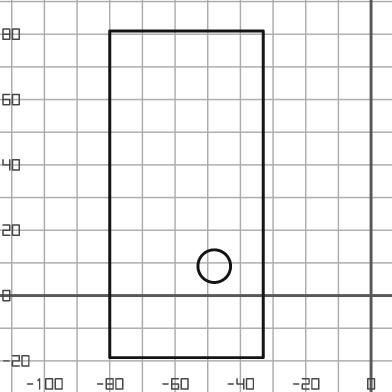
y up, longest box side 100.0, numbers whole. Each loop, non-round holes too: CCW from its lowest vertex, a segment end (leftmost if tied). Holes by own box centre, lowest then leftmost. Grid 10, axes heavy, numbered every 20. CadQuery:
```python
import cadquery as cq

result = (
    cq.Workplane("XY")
    .moveTo(-80.0, -19.0)
    .lineTo(-33.0, -19.0)
    .lineTo(-33.0, 81.0)
    .lineTo(-80.0, 81.0)
    .close()
    .moveTo(-48.0, 9.0)
    .circle(5.0)
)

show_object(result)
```